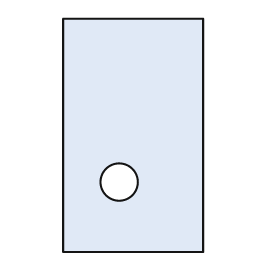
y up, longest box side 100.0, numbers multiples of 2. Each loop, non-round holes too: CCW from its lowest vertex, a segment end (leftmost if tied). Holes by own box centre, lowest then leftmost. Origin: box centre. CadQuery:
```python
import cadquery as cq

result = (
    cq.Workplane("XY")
    .moveTo(-30.0, -50.0)
    .lineTo(30.0, -50.0)
    .lineTo(30.0, 50.0)
    .lineTo(-30.0, 50.0)
    .close()
    .moveTo(-6.0, -20.0)
    .circle(8.0)
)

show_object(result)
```